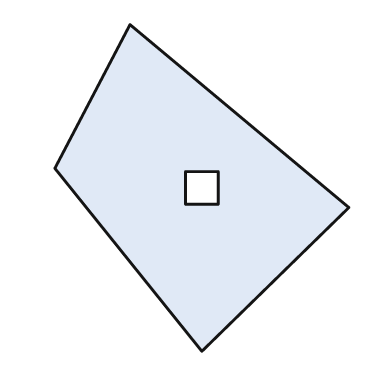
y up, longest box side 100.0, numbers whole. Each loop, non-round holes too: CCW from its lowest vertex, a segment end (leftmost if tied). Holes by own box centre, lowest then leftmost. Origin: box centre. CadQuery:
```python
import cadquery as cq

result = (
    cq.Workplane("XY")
    .moveTo(0.0, -50.0)
    .lineTo(45.0, -6.0)
    .lineTo(-22.0, 50.0)
    .lineTo(-45.0, 6.0)
    .close()
    .moveTo(-5.0, -5.0)
    .lineTo(5.0, -5.0)
    .lineTo(5.0, 5.0)
    .lineTo(-5.0, 5.0)
    .close()
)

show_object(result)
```